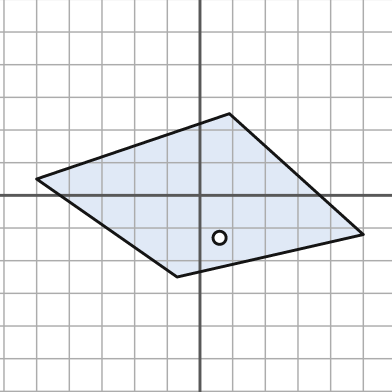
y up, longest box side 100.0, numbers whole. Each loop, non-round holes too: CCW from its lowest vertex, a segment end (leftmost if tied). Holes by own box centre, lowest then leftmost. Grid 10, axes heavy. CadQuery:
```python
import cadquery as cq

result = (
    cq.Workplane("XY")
    .moveTo(-7.0, -25.0)
    .lineTo(50.0, -12.0)
    .lineTo(9.0, 25.0)
    .lineTo(-50.0, 5.0)
    .close()
    .moveTo(6.0, -13.0)
    .circle(2.0)
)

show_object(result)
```